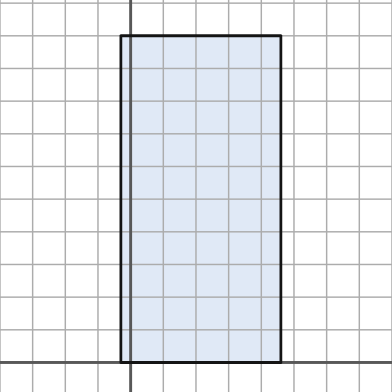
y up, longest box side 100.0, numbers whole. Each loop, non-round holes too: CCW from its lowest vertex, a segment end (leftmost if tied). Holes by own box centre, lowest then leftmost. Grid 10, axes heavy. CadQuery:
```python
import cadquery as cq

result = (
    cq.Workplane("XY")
    .moveTo(-3.0, 0.0)
    .lineTo(46.0, 0.0)
    .lineTo(46.0, 100.0)
    .lineTo(-3.0, 100.0)
    .close()
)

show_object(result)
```